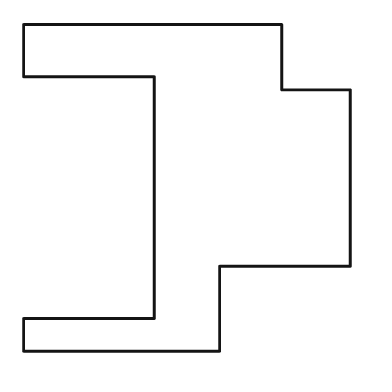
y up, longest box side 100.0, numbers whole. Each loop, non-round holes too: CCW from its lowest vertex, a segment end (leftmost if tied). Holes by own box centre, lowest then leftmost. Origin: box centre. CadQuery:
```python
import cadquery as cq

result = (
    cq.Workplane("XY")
    .moveTo(-50.0, -50.0)
    .lineTo(10.0, -50.0)
    .lineTo(10.0, -24.0)
    .lineTo(50.0, -24.0)
    .lineTo(50.0, 30.0)
    .lineTo(29.0, 30.0)
    .lineTo(29.0, 50.0)
    .lineTo(-50.0, 50.0)
    .lineTo(-50.0, 34.0)
    .lineTo(-10.0, 34.0)
    .lineTo(-10.0, -40.0)
    .lineTo(-50.0, -40.0)
    .close()
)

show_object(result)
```